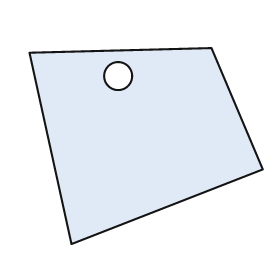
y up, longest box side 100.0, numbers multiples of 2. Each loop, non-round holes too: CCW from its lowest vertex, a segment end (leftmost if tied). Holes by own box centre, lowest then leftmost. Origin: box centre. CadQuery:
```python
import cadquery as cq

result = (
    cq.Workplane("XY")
    .moveTo(-32.0, -42.0)
    .lineTo(50.0, -10.0)
    .lineTo(28.0, 42.0)
    .lineTo(-50.0, 40.0)
    .close()
    .moveTo(-12.0, 30.0)
    .circle(6.0)
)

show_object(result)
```